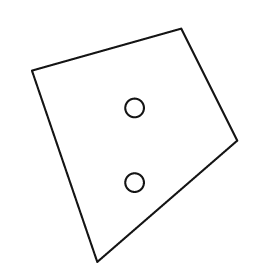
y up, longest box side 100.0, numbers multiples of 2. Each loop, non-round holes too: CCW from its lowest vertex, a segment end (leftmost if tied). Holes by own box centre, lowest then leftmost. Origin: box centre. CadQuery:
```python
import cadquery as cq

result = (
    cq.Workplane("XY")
    .moveTo(-16.0, -50.0)
    .lineTo(44.0, 2.0)
    .lineTo(20.0, 50.0)
    .lineTo(-44.0, 32.0)
    .close()
    .moveTo(0.0, -16.0)
    .circle(4.0)
    .moveTo(0.0, 16.0)
    .circle(4.0)
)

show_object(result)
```